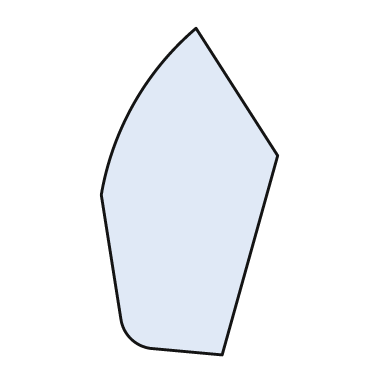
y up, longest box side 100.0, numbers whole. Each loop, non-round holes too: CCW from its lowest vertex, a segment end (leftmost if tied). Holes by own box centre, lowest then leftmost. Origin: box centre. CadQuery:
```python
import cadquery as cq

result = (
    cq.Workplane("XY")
    .moveTo(10.0, -50.0)
    .lineTo(27.0, 11.0)
    .lineTo(2.0, 50.0)
    .threePointArc((-17.0, 27.0), (-27.0, -1.0))
    .lineTo(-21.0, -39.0)
    .threePointArc((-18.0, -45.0), (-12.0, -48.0))
    .close()
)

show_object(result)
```